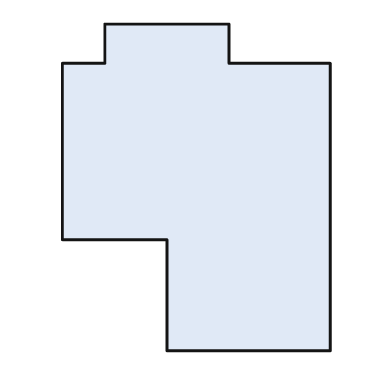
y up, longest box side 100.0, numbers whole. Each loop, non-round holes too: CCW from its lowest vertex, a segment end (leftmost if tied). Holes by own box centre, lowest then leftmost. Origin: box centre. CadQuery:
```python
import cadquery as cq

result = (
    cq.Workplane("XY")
    .moveTo(-9.0, -50.0)
    .lineTo(41.0, -50.0)
    .lineTo(41.0, 38.0)
    .lineTo(10.0, 38.0)
    .lineTo(10.0, 50.0)
    .lineTo(-28.0, 50.0)
    .lineTo(-28.0, 38.0)
    .lineTo(-41.0, 38.0)
    .lineTo(-41.0, -16.0)
    .lineTo(-9.0, -16.0)
    .close()
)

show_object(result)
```